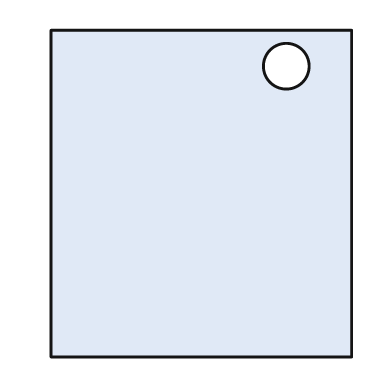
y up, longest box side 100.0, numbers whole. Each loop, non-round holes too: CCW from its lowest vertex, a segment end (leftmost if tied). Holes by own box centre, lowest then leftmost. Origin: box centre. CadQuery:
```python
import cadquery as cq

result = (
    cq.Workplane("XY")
    .moveTo(-46.0, -50.0)
    .lineTo(46.0, -50.0)
    .lineTo(46.0, 50.0)
    .lineTo(-46.0, 50.0)
    .close()
    .moveTo(26.0, 39.0)
    .circle(7.0)
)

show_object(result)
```